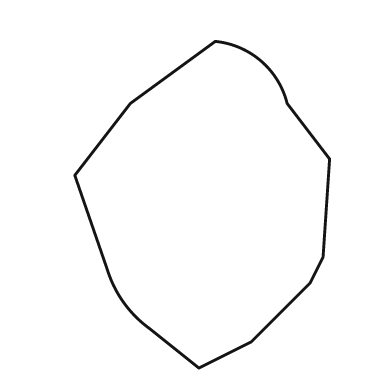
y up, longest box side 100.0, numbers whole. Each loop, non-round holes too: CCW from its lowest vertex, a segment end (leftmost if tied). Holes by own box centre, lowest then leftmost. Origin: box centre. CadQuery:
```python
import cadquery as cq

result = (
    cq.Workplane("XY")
    .moveTo(-1.0, -50.0)
    .lineTo(15.0, -42.0)
    .lineTo(33.0, -24.0)
    .lineTo(37.0, -16.0)
    .lineTo(39.0, 14.0)
    .lineTo(26.0, 31.0)
    .threePointArc((18.0, 44.0), (4.0, 50.0))
    .lineTo(-22.0, 31.0)
    .lineTo(-39.0, 9.0)
    .lineTo(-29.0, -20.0)
    .threePointArc((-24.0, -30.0), (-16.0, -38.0))
    .close()
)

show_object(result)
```